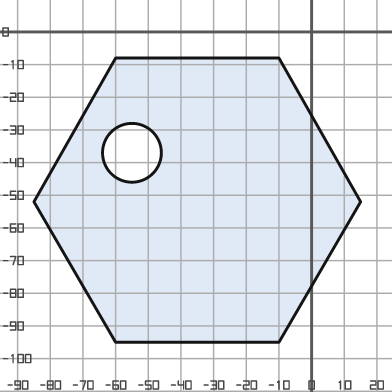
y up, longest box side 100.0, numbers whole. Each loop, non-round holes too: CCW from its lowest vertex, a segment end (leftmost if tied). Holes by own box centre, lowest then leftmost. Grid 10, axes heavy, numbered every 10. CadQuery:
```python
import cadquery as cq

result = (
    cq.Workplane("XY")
    .moveTo(-60.0, -95.0)
    .lineTo(-10.0, -95.0)
    .lineTo(15.0, -52.0)
    .lineTo(-10.0, -8.0)
    .lineTo(-60.0, -8.0)
    .lineTo(-85.0, -52.0)
    .close()
    .moveTo(-55.0, -37.0)
    .circle(9.0)
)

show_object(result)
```